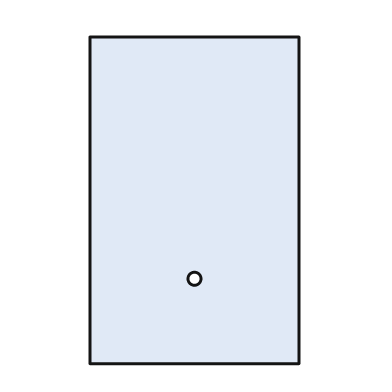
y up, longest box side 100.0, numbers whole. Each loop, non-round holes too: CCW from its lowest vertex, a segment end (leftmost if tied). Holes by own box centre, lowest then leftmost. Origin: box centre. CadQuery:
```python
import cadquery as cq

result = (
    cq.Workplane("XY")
    .moveTo(-32.0, -50.0)
    .lineTo(32.0, -50.0)
    .lineTo(32.0, 50.0)
    .lineTo(-32.0, 50.0)
    .close()
    .moveTo(0.0, -24.0)
    .circle(2.0)
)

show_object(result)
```